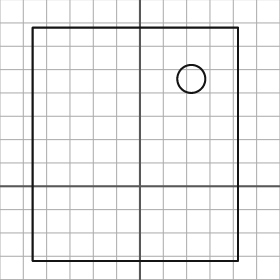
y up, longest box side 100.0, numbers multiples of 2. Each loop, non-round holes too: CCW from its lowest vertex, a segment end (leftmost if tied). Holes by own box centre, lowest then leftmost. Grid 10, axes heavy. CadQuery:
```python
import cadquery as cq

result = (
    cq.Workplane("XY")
    .moveTo(-46.0, -32.0)
    .lineTo(42.0, -32.0)
    .lineTo(42.0, 68.0)
    .lineTo(-46.0, 68.0)
    .close()
    .moveTo(22.0, 46.0)
    .circle(6.0)
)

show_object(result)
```